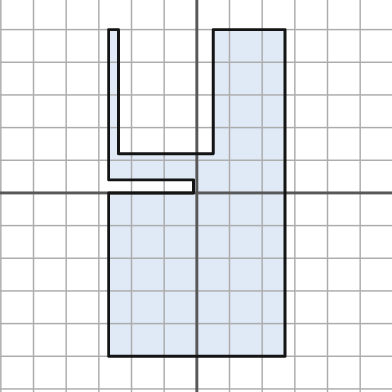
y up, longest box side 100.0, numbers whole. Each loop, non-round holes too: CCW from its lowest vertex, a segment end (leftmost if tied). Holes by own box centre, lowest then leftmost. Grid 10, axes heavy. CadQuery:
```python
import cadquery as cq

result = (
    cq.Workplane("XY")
    .moveTo(-27.0, -50.0)
    .lineTo(27.0, -50.0)
    .lineTo(27.0, 50.0)
    .lineTo(5.0, 50.0)
    .lineTo(5.0, 12.0)
    .lineTo(-24.0, 12.0)
    .lineTo(-24.0, 50.0)
    .lineTo(-27.0, 50.0)
    .lineTo(-27.0, 4.0)
    .lineTo(-1.0, 4.0)
    .lineTo(-1.0, 0.0)
    .lineTo(-27.0, 0.0)
    .close()
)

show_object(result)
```